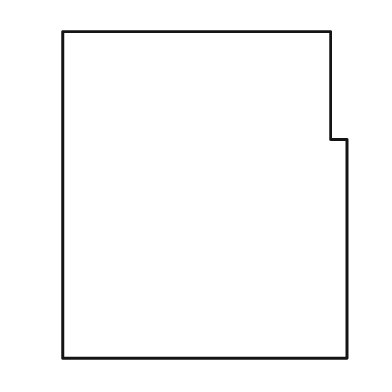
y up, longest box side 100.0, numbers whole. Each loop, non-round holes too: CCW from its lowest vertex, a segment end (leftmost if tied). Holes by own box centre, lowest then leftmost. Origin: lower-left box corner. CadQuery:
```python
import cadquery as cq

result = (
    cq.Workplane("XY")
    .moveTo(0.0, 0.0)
    .lineTo(87.0, 0.0)
    .lineTo(87.0, 67.0)
    .lineTo(82.0, 67.0)
    .lineTo(82.0, 100.0)
    .lineTo(0.0, 100.0)
    .close()
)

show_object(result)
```